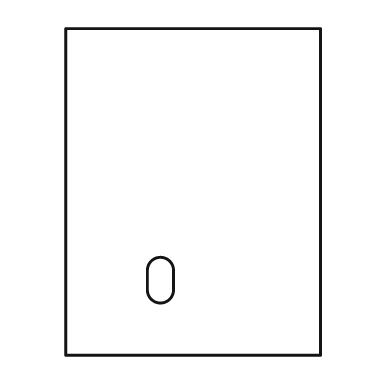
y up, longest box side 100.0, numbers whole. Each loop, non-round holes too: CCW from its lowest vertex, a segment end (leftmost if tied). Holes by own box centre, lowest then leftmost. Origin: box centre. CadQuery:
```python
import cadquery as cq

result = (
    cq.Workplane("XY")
    .moveTo(-39.0, -50.0)
    .lineTo(39.0, -50.0)
    .lineTo(39.0, 50.0)
    .lineTo(-39.0, 50.0)
    .close()
    .moveTo(-14.0, -30.0)
    .threePointArc((-10.0, -34.0), (-6.0, -30.0))
    .lineTo(-6.0, -24.0)
    .threePointArc((-10.0, -20.0), (-14.0, -24.0))
    .close()
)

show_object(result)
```